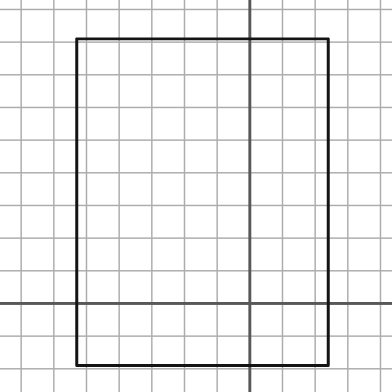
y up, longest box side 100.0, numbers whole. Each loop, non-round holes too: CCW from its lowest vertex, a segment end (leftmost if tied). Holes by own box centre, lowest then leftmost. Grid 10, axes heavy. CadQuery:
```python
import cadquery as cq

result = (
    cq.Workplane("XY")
    .moveTo(-53.0, -19.0)
    .lineTo(24.0, -19.0)
    .lineTo(24.0, 81.0)
    .lineTo(-53.0, 81.0)
    .close()
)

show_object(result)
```